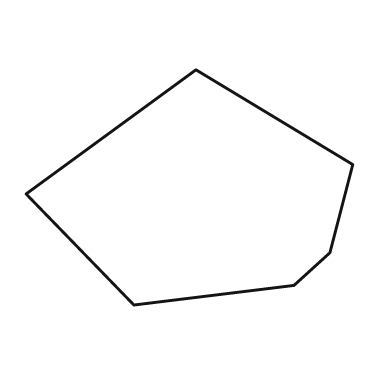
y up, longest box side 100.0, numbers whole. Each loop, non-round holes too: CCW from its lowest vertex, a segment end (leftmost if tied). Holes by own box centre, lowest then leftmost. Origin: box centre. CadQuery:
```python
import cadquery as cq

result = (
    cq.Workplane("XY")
    .moveTo(-17.0, -36.0)
    .lineTo(32.0, -30.0)
    .lineTo(43.0, -20.0)
    .lineTo(50.0, 7.0)
    .lineTo(2.0, 36.0)
    .lineTo(-50.0, -2.0)
    .close()
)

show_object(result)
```